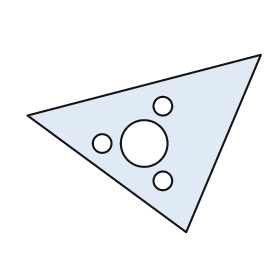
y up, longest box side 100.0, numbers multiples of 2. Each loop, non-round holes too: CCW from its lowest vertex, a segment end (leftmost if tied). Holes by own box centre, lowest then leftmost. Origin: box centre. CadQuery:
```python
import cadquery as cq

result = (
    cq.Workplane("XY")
    .moveTo(18.0, -38.0)
    .lineTo(50.0, 38.0)
    .lineTo(-50.0, 12.0)
    .close()
    .moveTo(8.0, -16.0)
    .circle(4.0)
    .moveTo(-18.0, 0.0)
    .circle(4.0)
    .moveTo(0.0, 0.0)
    .circle(10.0)
    .moveTo(8.0, 16.0)
    .circle(4.0)
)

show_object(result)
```